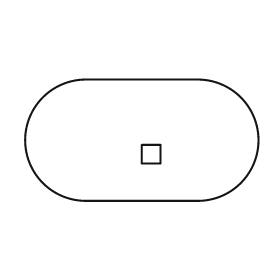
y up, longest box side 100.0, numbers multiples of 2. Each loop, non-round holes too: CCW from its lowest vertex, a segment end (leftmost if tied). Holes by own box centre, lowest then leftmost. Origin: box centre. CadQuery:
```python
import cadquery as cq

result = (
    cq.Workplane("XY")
    .moveTo(-24.0, -26.0)
    .lineTo(24.0, -26.0)
    .threePointArc((50.0, 0.0), (24.0, 26.0))
    .lineTo(-24.0, 26.0)
    .threePointArc((-50.0, 0.0), (-24.0, -26.0))
    .close()
    .moveTo(0.0, -10.0)
    .lineTo(8.0, -10.0)
    .lineTo(8.0, -2.0)
    .lineTo(0.0, -2.0)
    .close()
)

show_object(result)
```